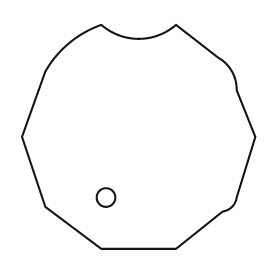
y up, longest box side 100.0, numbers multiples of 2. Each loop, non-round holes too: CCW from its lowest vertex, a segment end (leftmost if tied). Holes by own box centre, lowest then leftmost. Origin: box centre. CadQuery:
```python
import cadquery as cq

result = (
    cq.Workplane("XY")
    .moveTo(-16.0, -48.0)
    .lineTo(16.0, -48.0)
    .lineTo(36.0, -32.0)
    .threePointArc((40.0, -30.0), (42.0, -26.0))
    .lineTo(50.0, 0.0)
    .lineTo(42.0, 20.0)
    .threePointArc((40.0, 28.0), (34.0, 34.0))
    .lineTo(16.0, 48.0)
    .threePointArc((0.0, 42.0), (-16.0, 48.0))
    .threePointArc((-30.0, 40.0), (-40.0, 28.0))
    .lineTo(-50.0, 0.0)
    .lineTo(-40.0, -30.0)
    .close()
    .moveTo(-14.0, -26.0)
    .circle(4.0)
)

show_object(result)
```